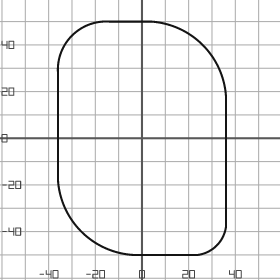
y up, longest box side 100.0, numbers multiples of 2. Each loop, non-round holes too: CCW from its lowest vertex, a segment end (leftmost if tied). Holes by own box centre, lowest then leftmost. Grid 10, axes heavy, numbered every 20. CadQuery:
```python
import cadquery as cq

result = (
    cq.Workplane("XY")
    .moveTo(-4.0, -50.0)
    .lineTo(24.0, -50.0)
    .threePointArc((32.0, -46.0), (36.0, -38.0))
    .lineTo(36.0, 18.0)
    .threePointArc((26.0, 40.0), (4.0, 50.0))
    .lineTo(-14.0, 50.0)
    .threePointArc((-30.0, 44.0), (-36.0, 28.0))
    .lineTo(-36.0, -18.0)
    .threePointArc((-26.0, -40.0), (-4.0, -50.0))
    .close()
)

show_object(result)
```